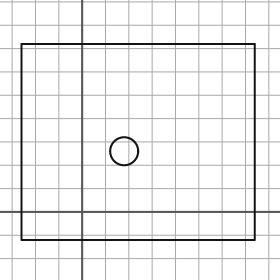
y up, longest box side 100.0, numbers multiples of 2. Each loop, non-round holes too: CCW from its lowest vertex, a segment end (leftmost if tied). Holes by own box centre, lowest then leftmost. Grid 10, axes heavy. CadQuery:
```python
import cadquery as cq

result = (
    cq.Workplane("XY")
    .moveTo(-26.0, -12.0)
    .lineTo(74.0, -12.0)
    .lineTo(74.0, 72.0)
    .lineTo(-26.0, 72.0)
    .close()
    .moveTo(18.0, 26.0)
    .circle(6.0)
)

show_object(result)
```